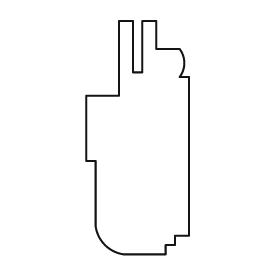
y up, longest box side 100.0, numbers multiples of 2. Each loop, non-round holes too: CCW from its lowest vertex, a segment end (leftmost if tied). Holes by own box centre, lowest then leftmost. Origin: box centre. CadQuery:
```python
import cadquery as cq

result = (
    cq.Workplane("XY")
    .moveTo(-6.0, -50.0)
    .lineTo(12.0, -50.0)
    .lineTo(12.0, -46.0)
    .lineTo(16.0, -46.0)
    .lineTo(16.0, -42.0)
    .lineTo(22.0, -42.0)
    .lineTo(22.0, 26.0)
    .lineTo(18.0, 26.0)
    .threePointArc((20.0, 32.0), (18.0, 38.0))
    .lineTo(8.0, 38.0)
    .lineTo(8.0, 50.0)
    .lineTo(2.0, 50.0)
    .lineTo(2.0, 28.0)
    .lineTo(-2.0, 28.0)
    .lineTo(-2.0, 50.0)
    .lineTo(-8.0, 50.0)
    .lineTo(-8.0, 18.0)
    .lineTo(-22.0, 18.0)
    .lineTo(-22.0, -10.0)
    .lineTo(-18.0, -10.0)
    .lineTo(-18.0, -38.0)
    .threePointArc((-14.0, -46.0), (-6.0, -50.0))
    .close()
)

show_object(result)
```